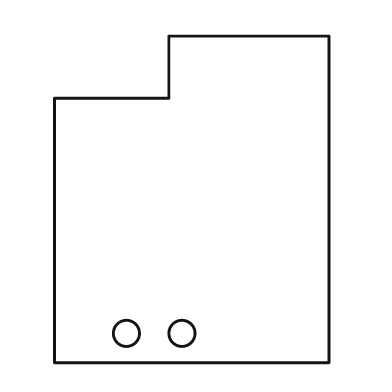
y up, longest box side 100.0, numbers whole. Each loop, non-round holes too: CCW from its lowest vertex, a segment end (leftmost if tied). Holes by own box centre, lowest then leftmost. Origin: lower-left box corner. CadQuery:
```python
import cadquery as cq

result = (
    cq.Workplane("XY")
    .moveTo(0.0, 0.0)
    .lineTo(84.0, 0.0)
    .lineTo(84.0, 100.0)
    .lineTo(35.0, 100.0)
    .lineTo(35.0, 81.0)
    .lineTo(0.0, 81.0)
    .close()
    .moveTo(22.0, 9.0)
    .circle(4.0)
    .moveTo(39.0, 9.0)
    .circle(4.0)
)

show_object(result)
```